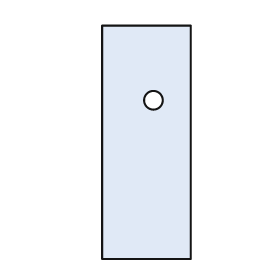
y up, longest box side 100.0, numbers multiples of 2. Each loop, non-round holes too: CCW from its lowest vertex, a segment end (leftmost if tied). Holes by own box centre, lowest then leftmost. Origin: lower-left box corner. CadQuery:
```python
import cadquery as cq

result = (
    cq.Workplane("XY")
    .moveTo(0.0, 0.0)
    .lineTo(38.0, 0.0)
    .lineTo(38.0, 100.0)
    .lineTo(0.0, 100.0)
    .close()
    .moveTo(22.0, 68.0)
    .circle(4.0)
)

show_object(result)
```